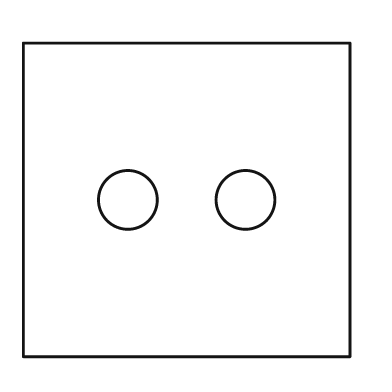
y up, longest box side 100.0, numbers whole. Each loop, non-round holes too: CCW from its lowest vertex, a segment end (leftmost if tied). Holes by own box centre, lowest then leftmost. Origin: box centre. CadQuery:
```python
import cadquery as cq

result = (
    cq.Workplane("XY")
    .moveTo(-50.0, -48.0)
    .lineTo(50.0, -48.0)
    .lineTo(50.0, 48.0)
    .lineTo(-50.0, 48.0)
    .close()
    .moveTo(-18.0, 0.0)
    .circle(9.0)
    .moveTo(18.0, 0.0)
    .circle(9.0)
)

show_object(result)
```